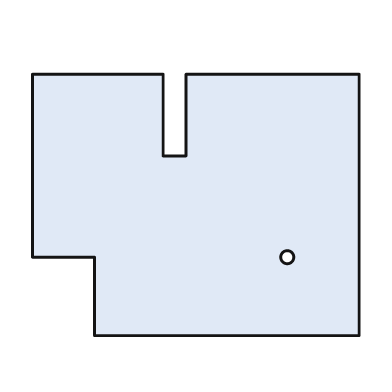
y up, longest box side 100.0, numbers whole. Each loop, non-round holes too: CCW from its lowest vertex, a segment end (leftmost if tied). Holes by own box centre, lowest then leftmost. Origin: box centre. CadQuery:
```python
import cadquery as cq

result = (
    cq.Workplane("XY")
    .moveTo(-31.0, -40.0)
    .lineTo(50.0, -40.0)
    .lineTo(50.0, 40.0)
    .lineTo(-3.0, 40.0)
    .lineTo(-3.0, 15.0)
    .lineTo(-10.0, 15.0)
    .lineTo(-10.0, 40.0)
    .lineTo(-50.0, 40.0)
    .lineTo(-50.0, -16.0)
    .lineTo(-31.0, -16.0)
    .close()
    .moveTo(28.0, -16.0)
    .circle(2.0)
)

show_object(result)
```